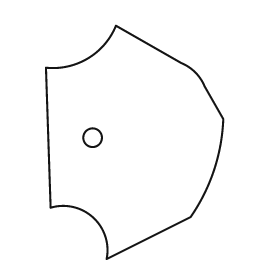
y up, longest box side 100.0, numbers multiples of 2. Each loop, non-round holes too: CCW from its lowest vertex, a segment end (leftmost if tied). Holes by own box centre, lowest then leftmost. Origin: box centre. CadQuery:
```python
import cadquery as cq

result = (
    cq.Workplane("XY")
    .moveTo(-12.0, -50.0)
    .lineTo(24.0, -32.0)
    .threePointArc((34.0, -12.0), (38.0, 10.0))
    .lineTo(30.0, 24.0)
    .threePointArc((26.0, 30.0), (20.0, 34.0))
    .lineTo(-8.0, 50.0)
    .threePointArc((-20.0, 36.0), (-38.0, 32.0))
    .lineTo(-36.0, -28.0)
    .threePointArc((-18.0, -32.0), (-12.0, -50.0))
    .close()
    .moveTo(-18.0, 2.0)
    .circle(4.0)
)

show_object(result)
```